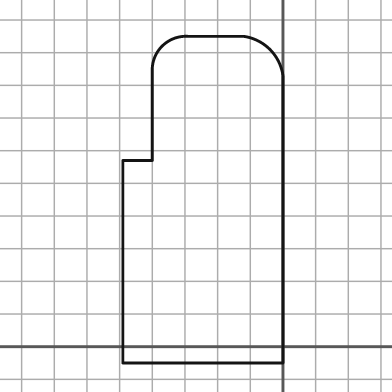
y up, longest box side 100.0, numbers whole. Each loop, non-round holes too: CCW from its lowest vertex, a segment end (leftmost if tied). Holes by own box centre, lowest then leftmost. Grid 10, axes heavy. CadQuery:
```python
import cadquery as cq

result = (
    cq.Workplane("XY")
    .moveTo(-49.0, -5.0)
    .lineTo(0.0, -5.0)
    .lineTo(0.0, 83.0)
    .threePointArc((-4.0, 91.0), (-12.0, 95.0))
    .lineTo(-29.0, 95.0)
    .threePointArc((-37.0, 92.0), (-40.0, 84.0))
    .lineTo(-40.0, 57.0)
    .lineTo(-49.0, 57.0)
    .close()
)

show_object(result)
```